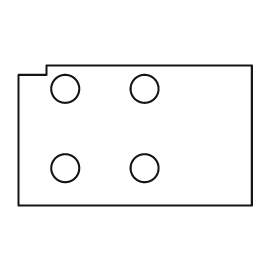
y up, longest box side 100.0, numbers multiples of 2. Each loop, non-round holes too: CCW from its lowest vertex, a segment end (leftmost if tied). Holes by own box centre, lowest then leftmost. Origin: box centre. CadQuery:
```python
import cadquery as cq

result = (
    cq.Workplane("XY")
    .moveTo(-50.0, -30.0)
    .lineTo(50.0, -30.0)
    .lineTo(50.0, 30.0)
    .lineTo(-38.0, 30.0)
    .lineTo(-38.0, 26.0)
    .lineTo(-50.0, 26.0)
    .close()
    .moveTo(-30.0, -14.0)
    .circle(6.0)
    .moveTo(4.0, -14.0)
    .circle(6.0)
    .moveTo(-30.0, 20.0)
    .circle(6.0)
    .moveTo(4.0, 20.0)
    .circle(6.0)
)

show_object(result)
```